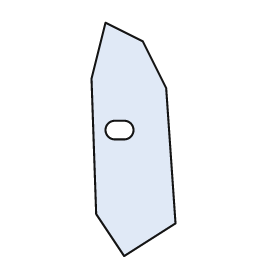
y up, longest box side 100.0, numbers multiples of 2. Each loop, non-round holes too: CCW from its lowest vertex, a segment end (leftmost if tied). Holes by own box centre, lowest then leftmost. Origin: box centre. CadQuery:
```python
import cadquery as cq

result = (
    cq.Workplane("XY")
    .moveTo(-4.0, -50.0)
    .lineTo(18.0, -36.0)
    .lineTo(14.0, 22.0)
    .lineTo(4.0, 42.0)
    .lineTo(-12.0, 50.0)
    .lineTo(-18.0, 26.0)
    .lineTo(-16.0, -32.0)
    .close()
    .moveTo(-8.0, 0.0)
    .lineTo(-4.0, 0.0)
    .threePointArc((0.0, 4.0), (-4.0, 8.0))
    .lineTo(-8.0, 8.0)
    .threePointArc((-12.0, 4.0), (-8.0, 0.0))
    .close()
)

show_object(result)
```